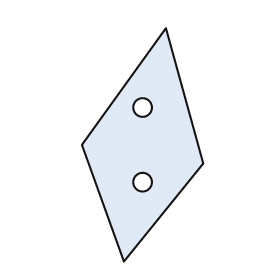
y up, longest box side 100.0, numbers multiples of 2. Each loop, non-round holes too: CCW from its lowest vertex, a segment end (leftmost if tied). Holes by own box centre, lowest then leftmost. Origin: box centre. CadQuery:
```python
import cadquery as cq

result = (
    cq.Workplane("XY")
    .moveTo(-8.0, -50.0)
    .lineTo(26.0, -8.0)
    .lineTo(10.0, 50.0)
    .lineTo(-26.0, 0.0)
    .close()
    .moveTo(0.0, -16.0)
    .circle(4.0)
    .moveTo(0.0, 16.0)
    .circle(4.0)
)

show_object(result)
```